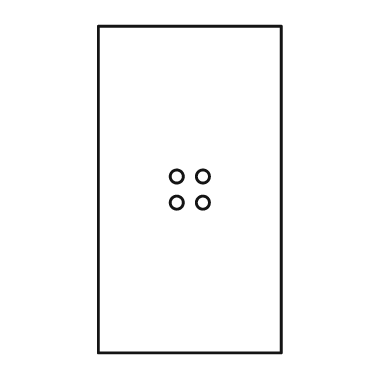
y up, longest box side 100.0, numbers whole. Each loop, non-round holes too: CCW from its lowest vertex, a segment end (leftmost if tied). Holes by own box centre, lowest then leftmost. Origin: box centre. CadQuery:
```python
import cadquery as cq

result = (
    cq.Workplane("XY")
    .moveTo(-28.0, -50.0)
    .lineTo(28.0, -50.0)
    .lineTo(28.0, 50.0)
    .lineTo(-28.0, 50.0)
    .close()
    .moveTo(-4.0, -4.0)
    .circle(2.0)
    .moveTo(4.0, -4.0)
    .circle(2.0)
    .moveTo(-4.0, 4.0)
    .circle(2.0)
    .moveTo(4.0, 4.0)
    .circle(2.0)
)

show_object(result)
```